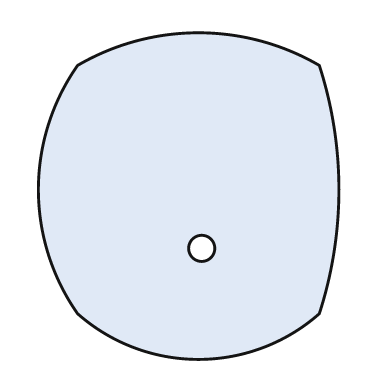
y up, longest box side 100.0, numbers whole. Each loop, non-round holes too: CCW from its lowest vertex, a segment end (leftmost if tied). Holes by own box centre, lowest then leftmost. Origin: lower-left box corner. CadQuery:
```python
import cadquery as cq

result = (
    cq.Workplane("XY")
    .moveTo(12.0, 14.0)
    .threePointArc((49.0, 0.0), (86.0, 14.0))
    .threePointArc((92.0, 52.0), (86.0, 90.0))
    .threePointArc((49.0, 100.0), (12.0, 90.0))
    .threePointArc((0.0, 52.0), (12.0, 14.0))
    .close()
    .moveTo(50.0, 34.0)
    .circle(4.0)
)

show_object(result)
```